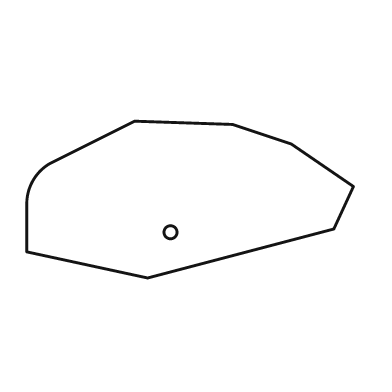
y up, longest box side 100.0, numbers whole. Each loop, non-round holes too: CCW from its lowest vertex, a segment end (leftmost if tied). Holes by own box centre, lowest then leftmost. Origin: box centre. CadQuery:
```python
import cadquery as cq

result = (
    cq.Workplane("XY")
    .moveTo(-13.0, -24.0)
    .lineTo(44.0, -9.0)
    .lineTo(50.0, 4.0)
    .lineTo(31.0, 17.0)
    .lineTo(13.0, 23.0)
    .lineTo(-17.0, 24.0)
    .lineTo(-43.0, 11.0)
    .threePointArc((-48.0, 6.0), (-50.0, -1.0))
    .lineTo(-50.0, -16.0)
    .close()
    .moveTo(-6.0, -10.0)
    .circle(2.0)
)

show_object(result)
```